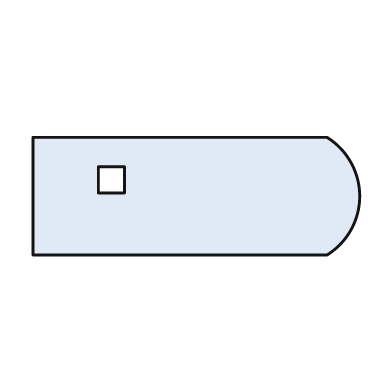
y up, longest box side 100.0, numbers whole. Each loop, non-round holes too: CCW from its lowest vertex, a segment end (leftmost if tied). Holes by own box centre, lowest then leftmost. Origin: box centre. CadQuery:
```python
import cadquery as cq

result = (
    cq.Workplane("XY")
    .moveTo(-50.0, -18.0)
    .lineTo(40.0, -18.0)
    .threePointArc((50.0, 0.0), (40.0, 18.0))
    .lineTo(-50.0, 18.0)
    .close()
    .moveTo(-30.0, 1.0)
    .lineTo(-22.0, 1.0)
    .lineTo(-22.0, 9.0)
    .lineTo(-30.0, 9.0)
    .close()
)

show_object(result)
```